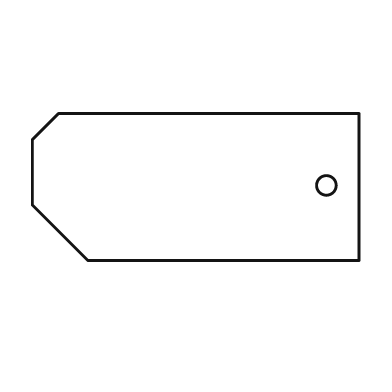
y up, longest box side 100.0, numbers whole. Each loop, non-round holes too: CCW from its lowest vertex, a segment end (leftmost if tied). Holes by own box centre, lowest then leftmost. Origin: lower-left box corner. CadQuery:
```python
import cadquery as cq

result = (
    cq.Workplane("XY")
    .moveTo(17.0, 0.0)
    .lineTo(100.0, 0.0)
    .lineTo(100.0, 45.0)
    .lineTo(8.0, 45.0)
    .lineTo(0.0, 37.0)
    .lineTo(0.0, 17.0)
    .close()
    .moveTo(90.0, 23.0)
    .circle(3.0)
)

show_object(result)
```